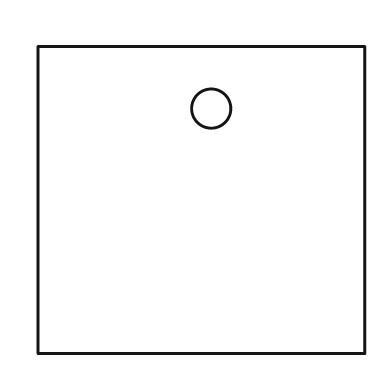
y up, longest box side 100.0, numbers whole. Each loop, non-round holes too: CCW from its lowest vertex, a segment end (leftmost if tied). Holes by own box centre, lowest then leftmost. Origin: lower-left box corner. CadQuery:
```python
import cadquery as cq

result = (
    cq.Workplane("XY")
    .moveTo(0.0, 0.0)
    .lineTo(100.0, 0.0)
    .lineTo(100.0, 94.0)
    .lineTo(0.0, 94.0)
    .close()
    .moveTo(53.0, 75.0)
    .circle(6.0)
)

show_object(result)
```